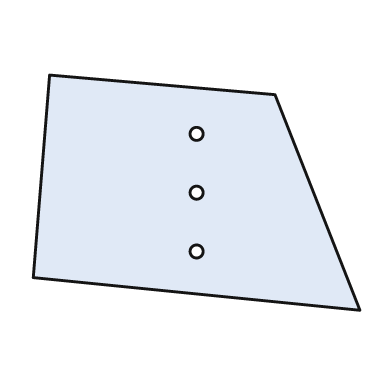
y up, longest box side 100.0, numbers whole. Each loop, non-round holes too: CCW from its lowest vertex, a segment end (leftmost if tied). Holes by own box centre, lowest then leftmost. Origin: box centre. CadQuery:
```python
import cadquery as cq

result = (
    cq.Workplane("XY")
    .moveTo(50.0, -36.0)
    .lineTo(24.0, 30.0)
    .lineTo(-45.0, 36.0)
    .lineTo(-50.0, -26.0)
    .close()
    .moveTo(0.0, -18.0)
    .circle(2.0)
    .moveTo(0.0, 0.0)
    .circle(2.0)
    .moveTo(0.0, 18.0)
    .circle(2.0)
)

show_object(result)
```